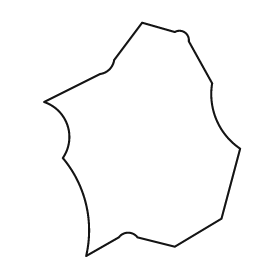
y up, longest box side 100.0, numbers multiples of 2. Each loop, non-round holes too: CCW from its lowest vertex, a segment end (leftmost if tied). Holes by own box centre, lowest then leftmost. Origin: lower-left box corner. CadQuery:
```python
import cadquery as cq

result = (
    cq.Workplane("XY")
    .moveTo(18.0, 0.0)
    .lineTo(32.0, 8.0)
    .threePointArc((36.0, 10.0), (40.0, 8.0))
    .lineTo(56.0, 4.0)
    .lineTo(76.0, 16.0)
    .lineTo(84.0, 46.0)
    .threePointArc((74.0, 58.0), (72.0, 74.0))
    .lineTo(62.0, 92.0)
    .threePointArc((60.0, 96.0), (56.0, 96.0))
    .lineTo(42.0, 100.0)
    .lineTo(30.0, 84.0)
    .threePointArc((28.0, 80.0), (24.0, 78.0))
    .lineTo(0.0, 66.0)
    .threePointArc((10.0, 56.0), (8.0, 42.0))
    .threePointArc((18.0, 22.0), (18.0, 0.0))
    .close()
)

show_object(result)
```